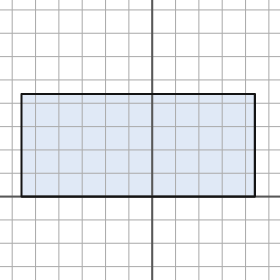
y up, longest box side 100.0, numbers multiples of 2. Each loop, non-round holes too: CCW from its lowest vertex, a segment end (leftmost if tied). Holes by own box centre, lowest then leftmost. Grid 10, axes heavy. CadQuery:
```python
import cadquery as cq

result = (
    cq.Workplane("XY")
    .moveTo(-56.0, 0.0)
    .lineTo(44.0, 0.0)
    .lineTo(44.0, 44.0)
    .lineTo(-56.0, 44.0)
    .close()
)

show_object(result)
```